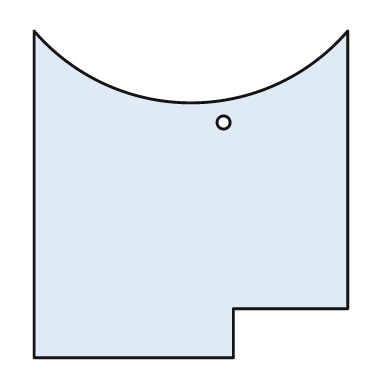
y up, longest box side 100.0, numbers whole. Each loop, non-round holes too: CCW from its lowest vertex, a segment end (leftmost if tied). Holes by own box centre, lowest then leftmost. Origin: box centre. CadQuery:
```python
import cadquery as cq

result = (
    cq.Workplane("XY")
    .moveTo(-48.0, -50.0)
    .lineTo(13.0, -50.0)
    .lineTo(13.0, -35.0)
    .lineTo(48.0, -35.0)
    .lineTo(48.0, 50.0)
    .threePointArc((0.0, 28.0), (-48.0, 50.0))
    .close()
    .moveTo(10.0, 22.0)
    .circle(2.0)
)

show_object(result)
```